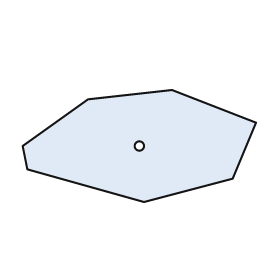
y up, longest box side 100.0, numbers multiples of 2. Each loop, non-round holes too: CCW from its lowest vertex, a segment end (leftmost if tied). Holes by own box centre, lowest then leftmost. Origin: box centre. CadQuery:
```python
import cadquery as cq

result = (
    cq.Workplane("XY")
    .moveTo(2.0, -24.0)
    .lineTo(40.0, -14.0)
    .lineTo(50.0, 10.0)
    .lineTo(14.0, 24.0)
    .lineTo(-22.0, 20.0)
    .lineTo(-50.0, 0.0)
    .lineTo(-48.0, -10.0)
    .close()
    .moveTo(0.0, 0.0)
    .circle(2.0)
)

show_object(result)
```